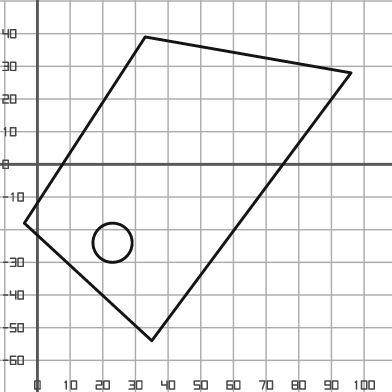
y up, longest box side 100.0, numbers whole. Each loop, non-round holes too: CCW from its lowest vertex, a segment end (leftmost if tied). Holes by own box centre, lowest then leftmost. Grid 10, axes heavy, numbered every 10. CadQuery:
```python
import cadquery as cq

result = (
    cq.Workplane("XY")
    .moveTo(35.0, -54.0)
    .lineTo(96.0, 28.0)
    .lineTo(33.0, 39.0)
    .lineTo(-4.0, -18.0)
    .close()
    .moveTo(23.0, -24.0)
    .circle(6.0)
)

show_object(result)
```